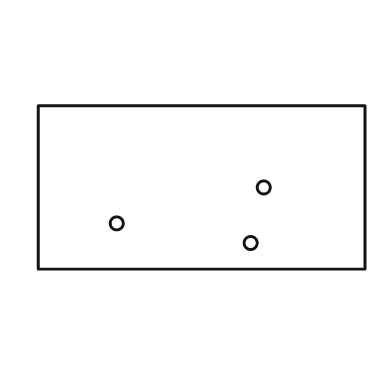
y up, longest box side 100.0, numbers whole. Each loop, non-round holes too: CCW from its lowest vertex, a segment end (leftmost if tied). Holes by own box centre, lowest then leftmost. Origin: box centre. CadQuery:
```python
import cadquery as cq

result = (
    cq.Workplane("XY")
    .moveTo(-50.0, -25.0)
    .lineTo(50.0, -25.0)
    .lineTo(50.0, 25.0)
    .lineTo(-50.0, 25.0)
    .close()
    .moveTo(15.0, -17.0)
    .circle(2.0)
    .moveTo(-26.0, -11.0)
    .circle(2.0)
    .moveTo(19.0, 0.0)
    .circle(2.0)
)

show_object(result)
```